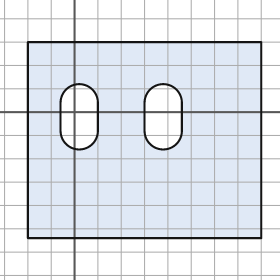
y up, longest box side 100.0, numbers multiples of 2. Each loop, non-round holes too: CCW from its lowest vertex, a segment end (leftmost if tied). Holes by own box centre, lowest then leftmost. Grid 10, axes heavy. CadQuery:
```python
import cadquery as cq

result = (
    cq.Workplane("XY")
    .moveTo(-20.0, -54.0)
    .lineTo(80.0, -54.0)
    .lineTo(80.0, 30.0)
    .lineTo(-20.0, 30.0)
    .close()
    .moveTo(-6.0, -8.0)
    .threePointArc((2.0, -16.0), (10.0, -8.0))
    .lineTo(10.0, 4.0)
    .threePointArc((2.0, 12.0), (-6.0, 4.0))
    .close()
    .moveTo(30.0, -8.0)
    .threePointArc((38.0, -16.0), (46.0, -8.0))
    .lineTo(46.0, 4.0)
    .threePointArc((38.0, 12.0), (30.0, 4.0))
    .close()
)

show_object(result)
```